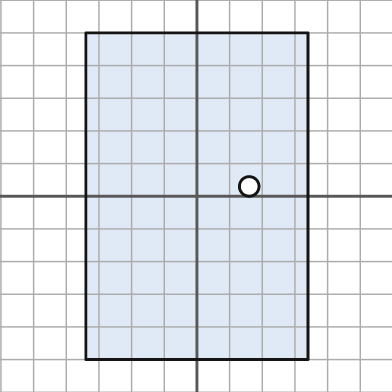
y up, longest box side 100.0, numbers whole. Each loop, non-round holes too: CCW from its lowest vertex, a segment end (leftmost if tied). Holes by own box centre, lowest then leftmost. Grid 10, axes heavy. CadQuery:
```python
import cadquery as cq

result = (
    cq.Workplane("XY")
    .moveTo(-34.0, -50.0)
    .lineTo(34.0, -50.0)
    .lineTo(34.0, 50.0)
    .lineTo(-34.0, 50.0)
    .close()
    .moveTo(16.0, 3.0)
    .circle(3.0)
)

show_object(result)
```